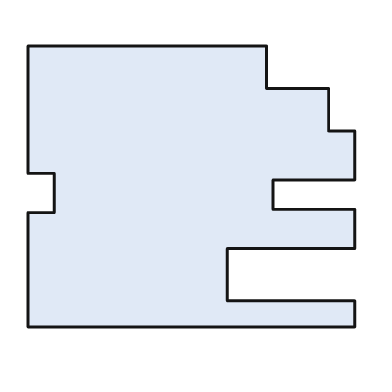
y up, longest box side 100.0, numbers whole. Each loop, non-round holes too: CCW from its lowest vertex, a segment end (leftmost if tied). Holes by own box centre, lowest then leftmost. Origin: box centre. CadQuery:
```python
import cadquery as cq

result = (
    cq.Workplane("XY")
    .moveTo(-50.0, -43.0)
    .lineTo(50.0, -43.0)
    .lineTo(50.0, -35.0)
    .lineTo(11.0, -35.0)
    .lineTo(11.0, -19.0)
    .lineTo(50.0, -19.0)
    .lineTo(50.0, -7.0)
    .lineTo(25.0, -7.0)
    .lineTo(25.0, 2.0)
    .lineTo(50.0, 2.0)
    .lineTo(50.0, 17.0)
    .lineTo(42.0, 17.0)
    .lineTo(42.0, 30.0)
    .lineTo(23.0, 30.0)
    .lineTo(23.0, 43.0)
    .lineTo(-50.0, 43.0)
    .lineTo(-50.0, 4.0)
    .lineTo(-42.0, 4.0)
    .lineTo(-42.0, -8.0)
    .lineTo(-50.0, -8.0)
    .close()
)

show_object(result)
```